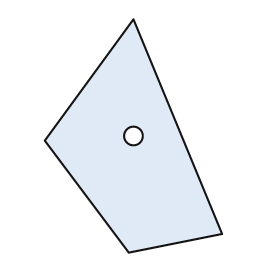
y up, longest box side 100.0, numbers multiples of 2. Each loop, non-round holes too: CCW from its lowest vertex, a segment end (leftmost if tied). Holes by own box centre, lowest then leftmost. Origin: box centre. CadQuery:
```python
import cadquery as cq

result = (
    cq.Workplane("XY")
    .moveTo(-2.0, -50.0)
    .lineTo(38.0, -42.0)
    .lineTo(0.0, 50.0)
    .lineTo(-38.0, -2.0)
    .close()
    .moveTo(0.0, 0.0)
    .circle(4.0)
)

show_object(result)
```